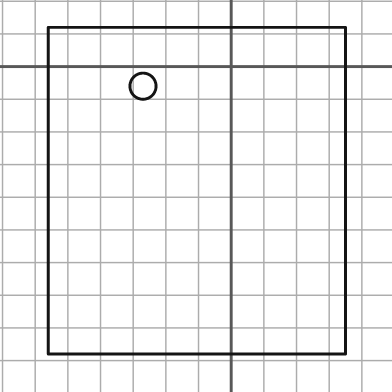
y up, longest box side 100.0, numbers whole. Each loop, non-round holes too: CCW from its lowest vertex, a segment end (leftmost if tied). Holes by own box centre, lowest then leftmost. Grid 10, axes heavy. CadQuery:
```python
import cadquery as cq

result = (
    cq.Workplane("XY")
    .moveTo(-56.0, -88.0)
    .lineTo(35.0, -88.0)
    .lineTo(35.0, 12.0)
    .lineTo(-56.0, 12.0)
    .close()
    .moveTo(-27.0, -6.0)
    .circle(4.0)
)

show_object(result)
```